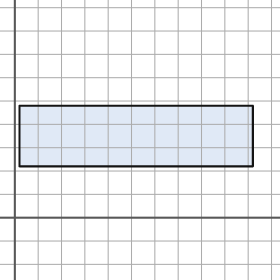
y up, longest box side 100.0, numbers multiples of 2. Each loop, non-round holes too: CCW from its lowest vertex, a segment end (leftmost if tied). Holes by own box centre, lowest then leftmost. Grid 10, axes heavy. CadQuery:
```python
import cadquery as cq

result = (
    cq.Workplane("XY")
    .moveTo(2.0, 22.0)
    .lineTo(102.0, 22.0)
    .lineTo(102.0, 48.0)
    .lineTo(2.0, 48.0)
    .close()
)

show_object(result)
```